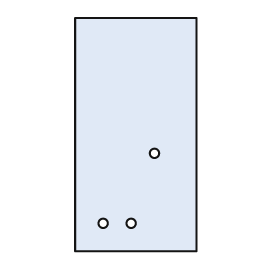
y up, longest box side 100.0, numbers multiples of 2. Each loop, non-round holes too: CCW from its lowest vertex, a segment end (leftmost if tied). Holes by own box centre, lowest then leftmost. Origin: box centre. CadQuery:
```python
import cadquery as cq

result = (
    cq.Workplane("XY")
    .moveTo(-26.0, -50.0)
    .lineTo(26.0, -50.0)
    .lineTo(26.0, 50.0)
    .lineTo(-26.0, 50.0)
    .close()
    .moveTo(-14.0, -38.0)
    .circle(2.0)
    .moveTo(-2.0, -38.0)
    .circle(2.0)
    .moveTo(8.0, -8.0)
    .circle(2.0)
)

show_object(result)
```